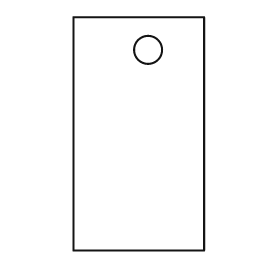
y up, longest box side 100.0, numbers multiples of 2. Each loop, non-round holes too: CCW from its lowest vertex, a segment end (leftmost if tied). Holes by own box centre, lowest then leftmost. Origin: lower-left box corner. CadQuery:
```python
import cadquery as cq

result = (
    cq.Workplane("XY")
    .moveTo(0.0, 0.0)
    .lineTo(56.0, 0.0)
    .lineTo(56.0, 100.0)
    .lineTo(0.0, 100.0)
    .close()
    .moveTo(32.0, 86.0)
    .circle(6.0)
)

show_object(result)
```